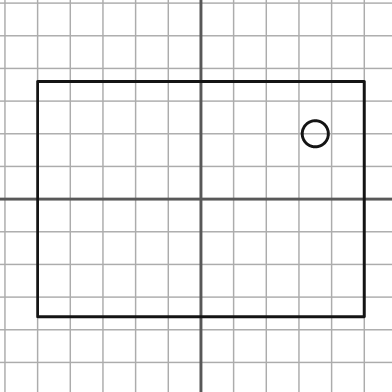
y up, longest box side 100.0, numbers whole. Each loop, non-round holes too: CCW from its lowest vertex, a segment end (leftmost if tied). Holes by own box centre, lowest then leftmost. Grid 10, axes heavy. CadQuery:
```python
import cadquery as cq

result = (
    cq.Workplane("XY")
    .moveTo(-50.0, -36.0)
    .lineTo(50.0, -36.0)
    .lineTo(50.0, 36.0)
    .lineTo(-50.0, 36.0)
    .close()
    .moveTo(35.0, 20.0)
    .circle(4.0)
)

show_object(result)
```